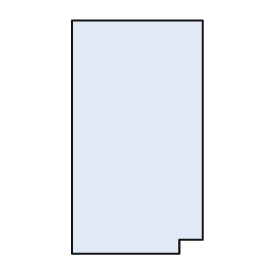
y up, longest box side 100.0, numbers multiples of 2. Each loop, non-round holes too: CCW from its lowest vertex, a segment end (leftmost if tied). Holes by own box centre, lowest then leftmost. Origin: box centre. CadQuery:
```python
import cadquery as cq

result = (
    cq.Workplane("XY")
    .moveTo(-28.0, -50.0)
    .lineTo(18.0, -50.0)
    .lineTo(18.0, -44.0)
    .lineTo(28.0, -44.0)
    .lineTo(28.0, 50.0)
    .lineTo(-28.0, 50.0)
    .close()
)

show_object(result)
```